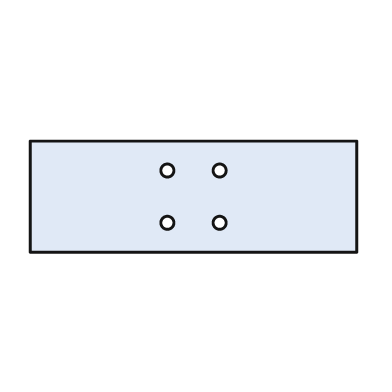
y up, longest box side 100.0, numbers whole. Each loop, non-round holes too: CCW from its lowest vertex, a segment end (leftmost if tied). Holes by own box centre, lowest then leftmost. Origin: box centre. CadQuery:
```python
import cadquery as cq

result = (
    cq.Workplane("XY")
    .moveTo(-50.0, -17.0)
    .lineTo(50.0, -17.0)
    .lineTo(50.0, 17.0)
    .lineTo(-50.0, 17.0)
    .close()
    .moveTo(-8.0, -8.0)
    .circle(2.0)
    .moveTo(8.0, -8.0)
    .circle(2.0)
    .moveTo(-8.0, 8.0)
    .circle(2.0)
    .moveTo(8.0, 8.0)
    .circle(2.0)
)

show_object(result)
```